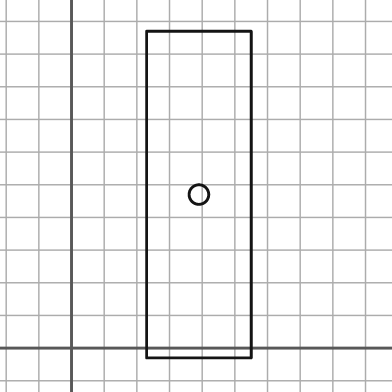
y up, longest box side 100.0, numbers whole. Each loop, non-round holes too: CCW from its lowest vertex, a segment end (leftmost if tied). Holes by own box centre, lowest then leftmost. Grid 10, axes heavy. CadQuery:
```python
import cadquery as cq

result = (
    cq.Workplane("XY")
    .moveTo(23.0, -3.0)
    .lineTo(55.0, -3.0)
    .lineTo(55.0, 97.0)
    .lineTo(23.0, 97.0)
    .close()
    .moveTo(39.0, 47.0)
    .circle(3.0)
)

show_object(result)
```